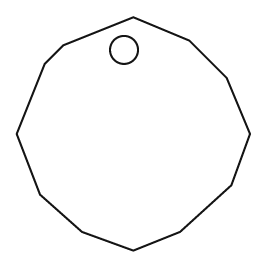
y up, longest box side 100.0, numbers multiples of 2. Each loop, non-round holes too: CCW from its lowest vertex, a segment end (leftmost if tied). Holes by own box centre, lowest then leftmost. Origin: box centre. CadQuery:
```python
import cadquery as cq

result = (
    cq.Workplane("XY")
    .moveTo(0.0, -50.0)
    .lineTo(20.0, -42.0)
    .lineTo(42.0, -22.0)
    .lineTo(50.0, 0.0)
    .lineTo(40.0, 24.0)
    .lineTo(24.0, 40.0)
    .lineTo(0.0, 50.0)
    .lineTo(-30.0, 38.0)
    .lineTo(-38.0, 30.0)
    .lineTo(-50.0, 0.0)
    .lineTo(-40.0, -26.0)
    .lineTo(-22.0, -42.0)
    .close()
    .moveTo(-4.0, 36.0)
    .circle(6.0)
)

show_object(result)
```